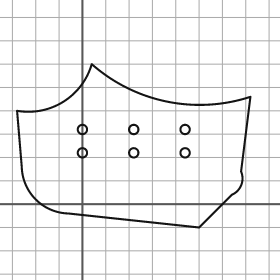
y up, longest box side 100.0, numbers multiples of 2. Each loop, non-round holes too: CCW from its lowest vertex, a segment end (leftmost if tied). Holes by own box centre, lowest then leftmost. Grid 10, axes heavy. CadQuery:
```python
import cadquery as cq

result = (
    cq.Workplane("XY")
    .moveTo(50.0, -10.0)
    .lineTo(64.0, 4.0)
    .threePointArc((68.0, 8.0), (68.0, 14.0))
    .lineTo(72.0, 46.0)
    .threePointArc((36.0, 44.0), (4.0, 60.0))
    .threePointArc((-8.0, 44.0), (-28.0, 40.0))
    .lineTo(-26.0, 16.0)
    .threePointArc((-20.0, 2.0), (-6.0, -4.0))
    .close()
    .moveTo(0.0, 22.0)
    .circle(2.0)
    .moveTo(22.0, 22.0)
    .circle(2.0)
    .moveTo(44.0, 22.0)
    .circle(2.0)
    .moveTo(0.0, 32.0)
    .circle(2.0)
    .moveTo(22.0, 32.0)
    .circle(2.0)
    .moveTo(44.0, 32.0)
    .circle(2.0)
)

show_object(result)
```